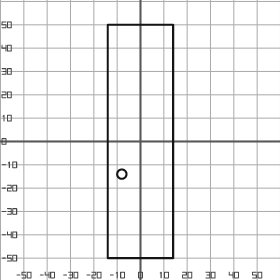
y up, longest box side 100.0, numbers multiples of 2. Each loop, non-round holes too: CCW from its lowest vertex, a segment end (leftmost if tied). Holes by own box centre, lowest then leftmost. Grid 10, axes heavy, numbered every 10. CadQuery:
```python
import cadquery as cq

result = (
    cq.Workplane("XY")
    .moveTo(-14.0, -50.0)
    .lineTo(14.0, -50.0)
    .lineTo(14.0, 50.0)
    .lineTo(-14.0, 50.0)
    .close()
    .moveTo(-8.0, -14.0)
    .circle(2.0)
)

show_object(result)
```